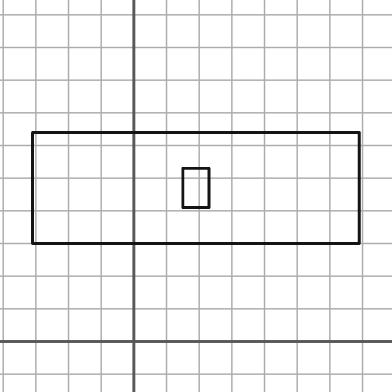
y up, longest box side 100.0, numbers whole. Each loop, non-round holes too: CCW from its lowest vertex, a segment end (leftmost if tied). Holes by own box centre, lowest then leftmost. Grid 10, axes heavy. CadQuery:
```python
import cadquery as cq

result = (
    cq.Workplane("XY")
    .moveTo(-31.0, 30.0)
    .lineTo(69.0, 30.0)
    .lineTo(69.0, 64.0)
    .lineTo(-31.0, 64.0)
    .close()
    .moveTo(15.0, 41.0)
    .lineTo(23.0, 41.0)
    .lineTo(23.0, 53.0)
    .lineTo(15.0, 53.0)
    .close()
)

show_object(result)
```